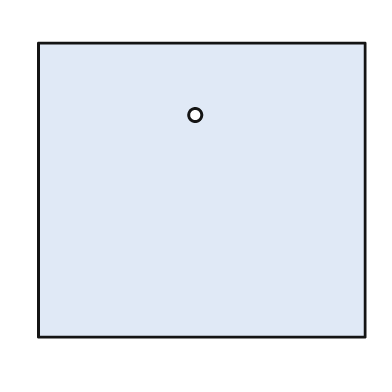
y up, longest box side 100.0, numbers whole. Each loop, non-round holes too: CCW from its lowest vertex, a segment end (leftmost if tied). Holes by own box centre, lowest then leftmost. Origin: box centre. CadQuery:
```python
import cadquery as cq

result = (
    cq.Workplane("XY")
    .moveTo(-50.0, -45.0)
    .lineTo(50.0, -45.0)
    .lineTo(50.0, 45.0)
    .lineTo(-50.0, 45.0)
    .close()
    .moveTo(-2.0, 23.0)
    .circle(2.0)
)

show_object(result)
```